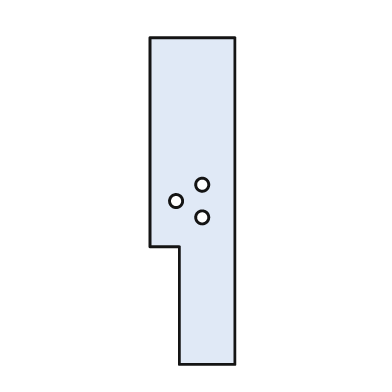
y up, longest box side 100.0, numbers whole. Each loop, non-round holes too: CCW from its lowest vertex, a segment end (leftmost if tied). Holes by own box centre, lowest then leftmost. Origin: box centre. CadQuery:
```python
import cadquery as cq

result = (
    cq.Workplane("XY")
    .moveTo(-4.0, -50.0)
    .lineTo(13.0, -50.0)
    .lineTo(13.0, 50.0)
    .lineTo(-13.0, 50.0)
    .lineTo(-13.0, -14.0)
    .lineTo(-4.0, -14.0)
    .close()
    .moveTo(3.0, -5.0)
    .circle(2.0)
    .moveTo(-5.0, 0.0)
    .circle(2.0)
    .moveTo(3.0, 5.0)
    .circle(2.0)
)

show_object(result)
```